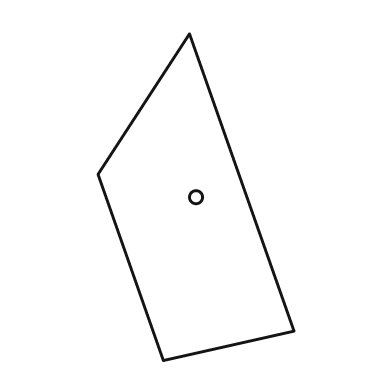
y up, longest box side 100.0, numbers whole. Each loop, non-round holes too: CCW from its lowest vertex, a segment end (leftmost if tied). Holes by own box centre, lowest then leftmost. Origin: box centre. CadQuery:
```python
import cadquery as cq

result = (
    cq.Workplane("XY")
    .moveTo(-10.0, -50.0)
    .lineTo(30.0, -41.0)
    .lineTo(-2.0, 50.0)
    .lineTo(-30.0, 7.0)
    .close()
    .moveTo(0.0, 0.0)
    .circle(2.0)
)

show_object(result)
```